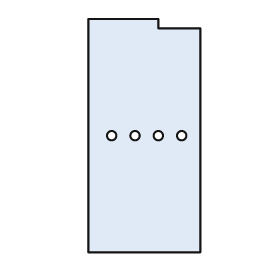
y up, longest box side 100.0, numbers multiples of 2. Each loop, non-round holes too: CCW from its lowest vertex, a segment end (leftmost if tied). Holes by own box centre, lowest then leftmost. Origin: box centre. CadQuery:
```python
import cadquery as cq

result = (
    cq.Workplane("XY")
    .moveTo(-24.0, -50.0)
    .lineTo(24.0, -50.0)
    .lineTo(24.0, 46.0)
    .lineTo(6.0, 46.0)
    .lineTo(6.0, 50.0)
    .lineTo(-24.0, 50.0)
    .close()
    .moveTo(-14.0, 0.0)
    .circle(2.0)
    .moveTo(-4.0, 0.0)
    .circle(2.0)
    .moveTo(6.0, 0.0)
    .circle(2.0)
    .moveTo(16.0, 0.0)
    .circle(2.0)
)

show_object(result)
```